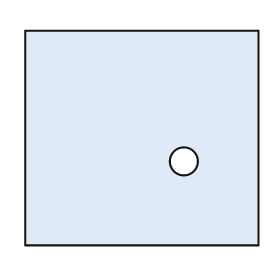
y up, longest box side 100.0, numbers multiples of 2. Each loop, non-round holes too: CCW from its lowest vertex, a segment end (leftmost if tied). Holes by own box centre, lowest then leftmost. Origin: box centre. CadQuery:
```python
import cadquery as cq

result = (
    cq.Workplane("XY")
    .moveTo(-50.0, -46.0)
    .lineTo(50.0, -46.0)
    .lineTo(50.0, 46.0)
    .lineTo(-50.0, 46.0)
    .close()
    .moveTo(18.0, -10.0)
    .circle(6.0)
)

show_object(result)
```